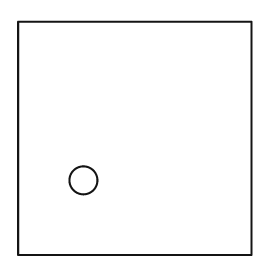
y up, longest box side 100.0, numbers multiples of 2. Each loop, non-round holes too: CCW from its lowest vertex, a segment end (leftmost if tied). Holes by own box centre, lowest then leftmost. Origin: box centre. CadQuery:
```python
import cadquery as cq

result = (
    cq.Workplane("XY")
    .moveTo(-50.0, -50.0)
    .lineTo(50.0, -50.0)
    .lineTo(50.0, 50.0)
    .lineTo(-50.0, 50.0)
    .close()
    .moveTo(-22.0, -18.0)
    .circle(6.0)
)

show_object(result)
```